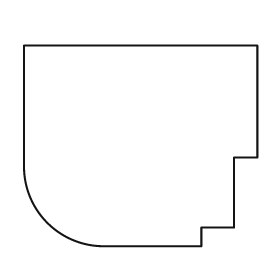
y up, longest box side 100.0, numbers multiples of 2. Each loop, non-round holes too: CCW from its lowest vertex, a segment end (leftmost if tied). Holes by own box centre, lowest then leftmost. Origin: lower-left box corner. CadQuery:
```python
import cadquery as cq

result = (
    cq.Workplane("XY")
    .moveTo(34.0, 0.0)
    .lineTo(76.0, 0.0)
    .lineTo(76.0, 8.0)
    .lineTo(90.0, 8.0)
    .lineTo(90.0, 38.0)
    .lineTo(100.0, 38.0)
    .lineTo(100.0, 86.0)
    .lineTo(0.0, 86.0)
    .lineTo(0.0, 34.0)
    .threePointArc((10.0, 10.0), (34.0, 0.0))
    .close()
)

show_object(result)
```